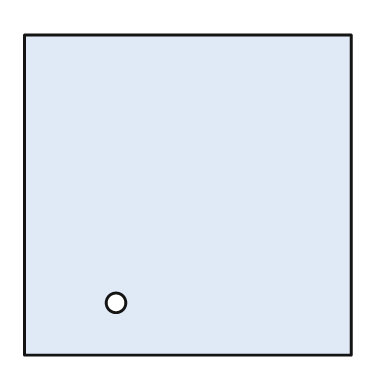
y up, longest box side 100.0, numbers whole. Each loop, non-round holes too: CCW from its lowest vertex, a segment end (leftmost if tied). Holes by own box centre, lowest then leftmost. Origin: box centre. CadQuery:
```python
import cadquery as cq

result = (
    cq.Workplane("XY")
    .moveTo(-50.0, -49.0)
    .lineTo(50.0, -49.0)
    .lineTo(50.0, 49.0)
    .lineTo(-50.0, 49.0)
    .close()
    .moveTo(-22.0, -33.0)
    .circle(3.0)
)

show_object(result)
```